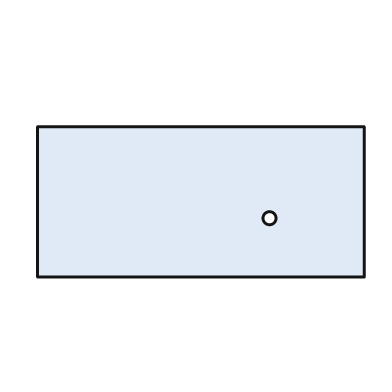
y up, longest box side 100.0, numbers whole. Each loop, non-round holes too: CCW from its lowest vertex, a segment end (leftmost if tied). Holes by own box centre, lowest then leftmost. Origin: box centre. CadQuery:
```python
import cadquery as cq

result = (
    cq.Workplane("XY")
    .moveTo(-50.0, -23.0)
    .lineTo(50.0, -23.0)
    .lineTo(50.0, 23.0)
    .lineTo(-50.0, 23.0)
    .close()
    .moveTo(21.0, -5.0)
    .circle(2.0)
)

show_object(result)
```